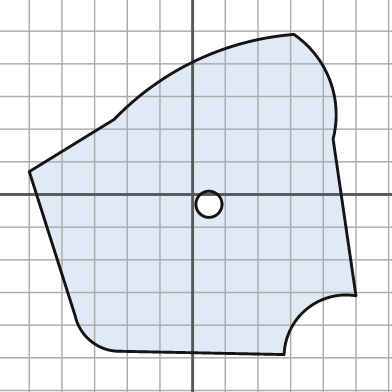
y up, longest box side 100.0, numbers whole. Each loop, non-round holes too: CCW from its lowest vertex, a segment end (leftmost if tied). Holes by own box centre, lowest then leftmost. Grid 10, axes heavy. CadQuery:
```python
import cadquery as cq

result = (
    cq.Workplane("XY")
    .moveTo(28.0, -49.0)
    .threePointArc((35.0, -35.0), (50.0, -31.0))
    .lineTo(43.0, 17.0)
    .threePointArc((42.0, 35.0), (31.0, 49.0))
    .threePointArc((1.0, 41.0), (-24.0, 23.0))
    .lineTo(-50.0, 7.0)
    .lineTo(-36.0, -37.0)
    .threePointArc((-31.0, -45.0), (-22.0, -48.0))
    .close()
    .moveTo(5.0, -3.0)
    .circle(4.0)
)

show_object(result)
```